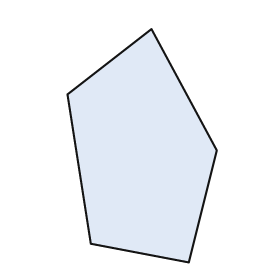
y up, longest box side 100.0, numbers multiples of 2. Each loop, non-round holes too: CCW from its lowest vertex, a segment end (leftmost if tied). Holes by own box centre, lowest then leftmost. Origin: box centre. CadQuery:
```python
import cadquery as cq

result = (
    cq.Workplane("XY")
    .moveTo(20.0, -50.0)
    .lineTo(32.0, -2.0)
    .lineTo(4.0, 50.0)
    .lineTo(-32.0, 22.0)
    .lineTo(-22.0, -42.0)
    .close()
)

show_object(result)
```